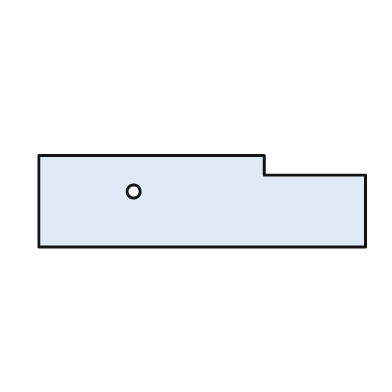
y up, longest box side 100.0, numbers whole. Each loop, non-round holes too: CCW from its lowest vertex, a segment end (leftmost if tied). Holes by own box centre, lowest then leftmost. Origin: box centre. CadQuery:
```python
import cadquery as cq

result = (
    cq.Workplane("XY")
    .moveTo(-50.0, -14.0)
    .lineTo(50.0, -14.0)
    .lineTo(50.0, 8.0)
    .lineTo(19.0, 8.0)
    .lineTo(19.0, 14.0)
    .lineTo(-50.0, 14.0)
    .close()
    .moveTo(-21.0, 3.0)
    .circle(2.0)
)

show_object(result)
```